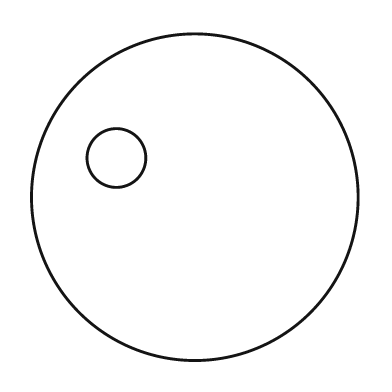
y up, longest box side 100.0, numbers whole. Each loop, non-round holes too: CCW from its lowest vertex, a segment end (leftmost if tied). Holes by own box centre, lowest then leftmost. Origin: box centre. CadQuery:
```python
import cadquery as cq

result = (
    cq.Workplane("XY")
    .moveTo(0.0, 0.0)
    .circle(50.0)
    .moveTo(-24.0, 12.0)
    .circle(9.0)
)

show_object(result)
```